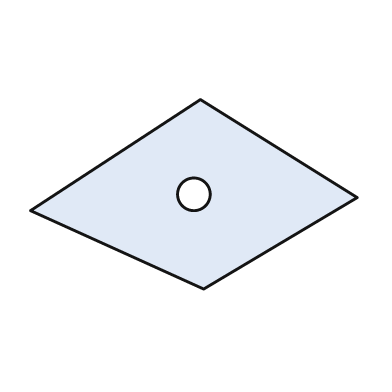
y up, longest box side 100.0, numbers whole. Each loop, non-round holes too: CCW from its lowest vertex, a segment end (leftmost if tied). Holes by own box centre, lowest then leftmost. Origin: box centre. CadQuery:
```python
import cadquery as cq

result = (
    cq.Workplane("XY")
    .moveTo(3.0, -29.0)
    .lineTo(50.0, -1.0)
    .lineTo(2.0, 29.0)
    .lineTo(-50.0, -5.0)
    .close()
    .moveTo(0.0, 0.0)
    .circle(5.0)
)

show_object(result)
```